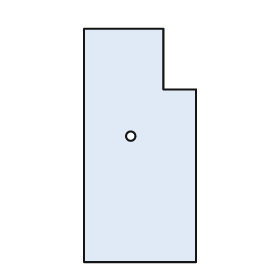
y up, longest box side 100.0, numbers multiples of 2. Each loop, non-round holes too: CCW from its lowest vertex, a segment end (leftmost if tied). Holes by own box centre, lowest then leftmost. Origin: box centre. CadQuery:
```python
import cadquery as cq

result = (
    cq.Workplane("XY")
    .moveTo(-24.0, -50.0)
    .lineTo(24.0, -50.0)
    .lineTo(24.0, 24.0)
    .lineTo(10.0, 24.0)
    .lineTo(10.0, 50.0)
    .lineTo(-24.0, 50.0)
    .close()
    .moveTo(-4.0, 4.0)
    .circle(2.0)
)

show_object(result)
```